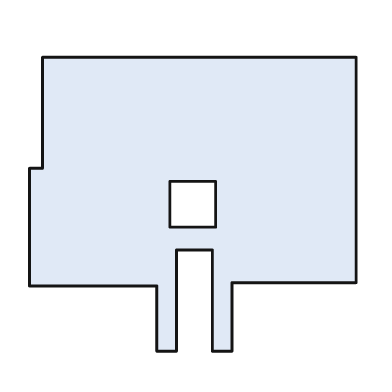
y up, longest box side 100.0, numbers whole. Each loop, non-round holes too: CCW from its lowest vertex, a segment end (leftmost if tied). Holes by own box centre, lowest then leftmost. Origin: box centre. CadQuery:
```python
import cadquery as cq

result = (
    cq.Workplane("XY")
    .moveTo(-11.0, -45.0)
    .lineTo(-5.0, -45.0)
    .lineTo(-5.0, -14.0)
    .lineTo(6.0, -14.0)
    .lineTo(6.0, -45.0)
    .lineTo(12.0, -45.0)
    .lineTo(12.0, -24.0)
    .lineTo(50.0, -24.0)
    .lineTo(50.0, 45.0)
    .lineTo(-46.0, 45.0)
    .lineTo(-46.0, 11.0)
    .lineTo(-50.0, 11.0)
    .lineTo(-50.0, -25.0)
    .lineTo(-11.0, -25.0)
    .close()
    .moveTo(-7.0, -7.0)
    .lineTo(7.0, -7.0)
    .lineTo(7.0, 7.0)
    .lineTo(-7.0, 7.0)
    .close()
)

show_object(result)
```